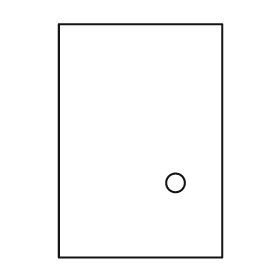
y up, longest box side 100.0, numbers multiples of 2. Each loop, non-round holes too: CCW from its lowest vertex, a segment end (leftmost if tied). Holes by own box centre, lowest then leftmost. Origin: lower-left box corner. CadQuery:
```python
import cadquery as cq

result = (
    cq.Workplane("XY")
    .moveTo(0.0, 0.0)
    .lineTo(70.0, 0.0)
    .lineTo(70.0, 100.0)
    .lineTo(0.0, 100.0)
    .close()
    .moveTo(50.0, 32.0)
    .circle(4.0)
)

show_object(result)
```